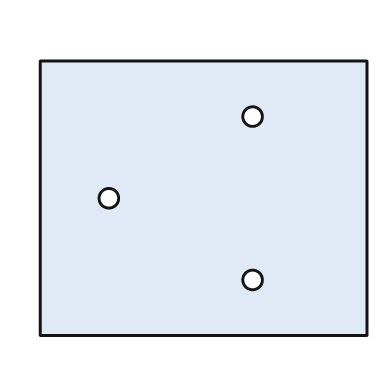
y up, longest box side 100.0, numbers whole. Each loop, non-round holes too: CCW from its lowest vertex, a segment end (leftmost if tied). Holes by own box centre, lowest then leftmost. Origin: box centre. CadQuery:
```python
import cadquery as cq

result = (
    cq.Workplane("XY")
    .moveTo(-50.0, -42.0)
    .lineTo(50.0, -42.0)
    .lineTo(50.0, 42.0)
    .lineTo(-50.0, 42.0)
    .close()
    .moveTo(15.0, -25.0)
    .circle(3.0)
    .moveTo(-29.0, 0.0)
    .circle(3.0)
    .moveTo(15.0, 25.0)
    .circle(3.0)
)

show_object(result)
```